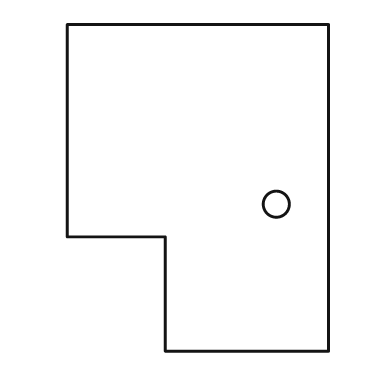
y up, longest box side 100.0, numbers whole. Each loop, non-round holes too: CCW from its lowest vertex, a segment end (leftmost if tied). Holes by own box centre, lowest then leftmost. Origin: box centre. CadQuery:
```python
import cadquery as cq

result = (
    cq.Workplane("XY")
    .moveTo(-10.0, -50.0)
    .lineTo(40.0, -50.0)
    .lineTo(40.0, 50.0)
    .lineTo(-40.0, 50.0)
    .lineTo(-40.0, -15.0)
    .lineTo(-10.0, -15.0)
    .close()
    .moveTo(24.0, -5.0)
    .circle(4.0)
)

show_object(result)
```